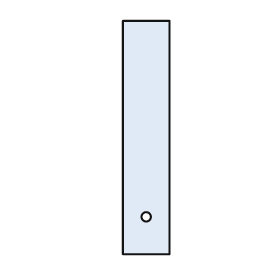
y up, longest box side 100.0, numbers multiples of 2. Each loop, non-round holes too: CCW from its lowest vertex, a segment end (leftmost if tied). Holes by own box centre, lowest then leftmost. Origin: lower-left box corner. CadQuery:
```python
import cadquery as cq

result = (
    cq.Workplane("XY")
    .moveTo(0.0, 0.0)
    .lineTo(20.0, 0.0)
    .lineTo(20.0, 100.0)
    .lineTo(0.0, 100.0)
    .close()
    .moveTo(10.0, 16.0)
    .circle(2.0)
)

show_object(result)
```